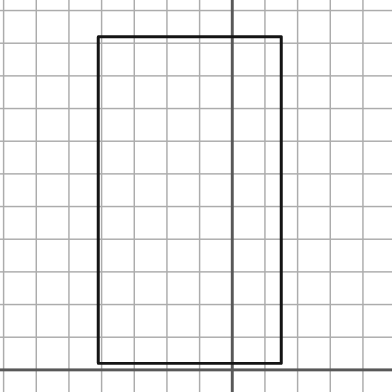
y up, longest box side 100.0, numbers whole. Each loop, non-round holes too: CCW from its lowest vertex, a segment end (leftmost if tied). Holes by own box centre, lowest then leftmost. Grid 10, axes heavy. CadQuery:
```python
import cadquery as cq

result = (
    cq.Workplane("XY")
    .moveTo(-41.0, 2.0)
    .lineTo(15.0, 2.0)
    .lineTo(15.0, 102.0)
    .lineTo(-41.0, 102.0)
    .close()
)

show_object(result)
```